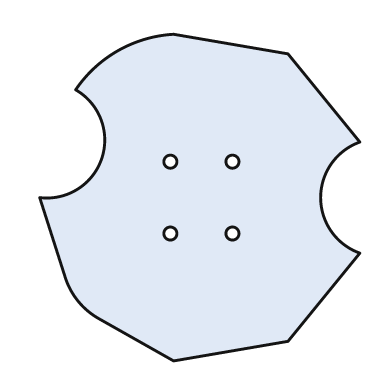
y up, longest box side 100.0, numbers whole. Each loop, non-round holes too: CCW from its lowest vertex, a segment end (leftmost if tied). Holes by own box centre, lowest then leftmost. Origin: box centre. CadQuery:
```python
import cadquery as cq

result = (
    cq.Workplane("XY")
    .moveTo(-8.0, -50.0)
    .lineTo(27.0, -44.0)
    .lineTo(49.0, -17.0)
    .threePointArc((37.0, 0.0), (49.0, 17.0))
    .lineTo(27.0, 44.0)
    .lineTo(-8.0, 50.0)
    .threePointArc((-25.0, 45.0), (-38.0, 33.0))
    .threePointArc((-30.0, 12.0), (-49.0, 0.0))
    .lineTo(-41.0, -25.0)
    .threePointArc((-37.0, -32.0), (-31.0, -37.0))
    .close()
    .moveTo(-9.0, -11.0)
    .circle(2.0)
    .moveTo(10.0, -11.0)
    .circle(2.0)
    .moveTo(-9.0, 11.0)
    .circle(2.0)
    .moveTo(10.0, 11.0)
    .circle(2.0)
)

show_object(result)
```